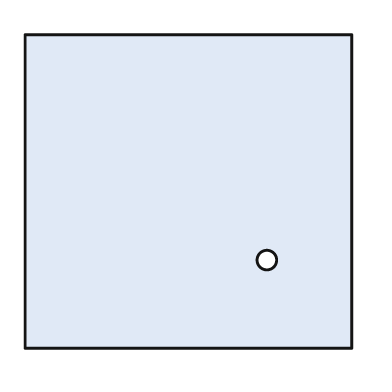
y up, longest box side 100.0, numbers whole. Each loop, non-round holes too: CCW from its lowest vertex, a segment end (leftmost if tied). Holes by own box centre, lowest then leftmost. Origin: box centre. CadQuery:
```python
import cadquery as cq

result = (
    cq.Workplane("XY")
    .moveTo(-50.0, -48.0)
    .lineTo(50.0, -48.0)
    .lineTo(50.0, 48.0)
    .lineTo(-50.0, 48.0)
    .close()
    .moveTo(24.0, -21.0)
    .circle(3.0)
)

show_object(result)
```